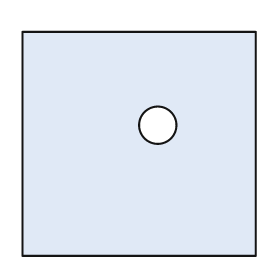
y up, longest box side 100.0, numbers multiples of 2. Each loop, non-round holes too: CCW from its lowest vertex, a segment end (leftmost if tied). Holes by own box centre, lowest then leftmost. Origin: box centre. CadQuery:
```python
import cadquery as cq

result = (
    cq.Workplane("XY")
    .moveTo(-50.0, -48.0)
    .lineTo(50.0, -48.0)
    .lineTo(50.0, 48.0)
    .lineTo(-50.0, 48.0)
    .close()
    .moveTo(8.0, 8.0)
    .circle(8.0)
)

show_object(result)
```